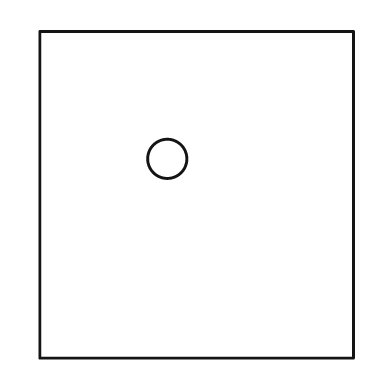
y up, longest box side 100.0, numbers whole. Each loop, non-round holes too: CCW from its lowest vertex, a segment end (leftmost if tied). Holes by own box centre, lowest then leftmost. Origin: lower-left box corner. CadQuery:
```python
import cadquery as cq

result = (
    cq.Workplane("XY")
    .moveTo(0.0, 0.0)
    .lineTo(96.0, 0.0)
    .lineTo(96.0, 100.0)
    .lineTo(0.0, 100.0)
    .close()
    .moveTo(39.0, 61.0)
    .circle(6.0)
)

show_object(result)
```